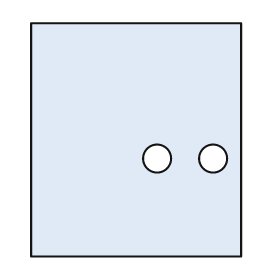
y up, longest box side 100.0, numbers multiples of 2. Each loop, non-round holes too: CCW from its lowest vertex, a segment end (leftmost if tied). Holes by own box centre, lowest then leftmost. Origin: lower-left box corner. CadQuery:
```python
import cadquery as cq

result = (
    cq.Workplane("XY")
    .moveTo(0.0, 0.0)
    .lineTo(90.0, 0.0)
    .lineTo(90.0, 100.0)
    .lineTo(0.0, 100.0)
    .close()
    .moveTo(54.0, 42.0)
    .circle(6.0)
    .moveTo(78.0, 42.0)
    .circle(6.0)
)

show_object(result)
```